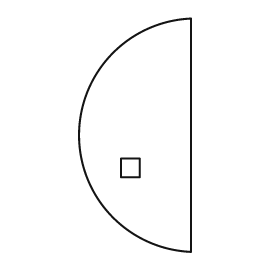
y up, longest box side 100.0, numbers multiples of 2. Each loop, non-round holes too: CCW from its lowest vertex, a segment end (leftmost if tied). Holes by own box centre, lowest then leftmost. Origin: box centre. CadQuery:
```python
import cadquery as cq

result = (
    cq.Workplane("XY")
    .moveTo(24.0, -50.0)
    .lineTo(24.0, 50.0)
    .threePointArc((-24.0, 0.0), (24.0, -50.0))
    .close()
    .moveTo(-6.0, -18.0)
    .lineTo(2.0, -18.0)
    .lineTo(2.0, -10.0)
    .lineTo(-6.0, -10.0)
    .close()
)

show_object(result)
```